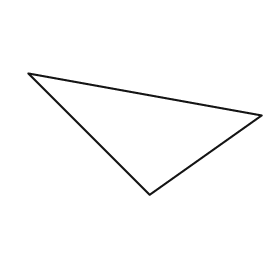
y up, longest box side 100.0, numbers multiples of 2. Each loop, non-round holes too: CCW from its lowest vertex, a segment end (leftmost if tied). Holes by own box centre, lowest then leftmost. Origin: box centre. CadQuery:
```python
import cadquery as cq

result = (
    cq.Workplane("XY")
    .moveTo(2.0, -26.0)
    .lineTo(50.0, 8.0)
    .lineTo(-50.0, 26.0)
    .close()
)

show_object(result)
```